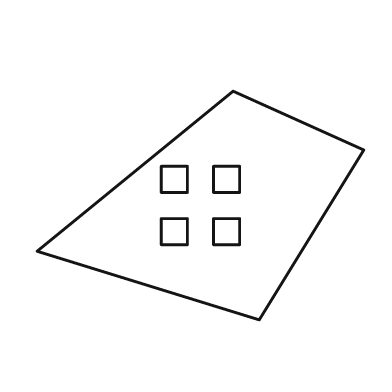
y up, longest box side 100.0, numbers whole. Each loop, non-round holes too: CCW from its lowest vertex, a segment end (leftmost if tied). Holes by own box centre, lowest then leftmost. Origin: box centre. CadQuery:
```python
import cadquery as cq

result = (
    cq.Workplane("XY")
    .moveTo(18.0, -35.0)
    .lineTo(50.0, 17.0)
    .lineTo(10.0, 35.0)
    .lineTo(-50.0, -14.0)
    .close()
    .moveTo(-12.0, -12.0)
    .lineTo(-4.0, -12.0)
    .lineTo(-4.0, -4.0)
    .lineTo(-12.0, -4.0)
    .close()
    .moveTo(4.0, -12.0)
    .lineTo(12.0, -12.0)
    .lineTo(12.0, -4.0)
    .lineTo(4.0, -4.0)
    .close()
    .moveTo(-12.0, 4.0)
    .lineTo(-4.0, 4.0)
    .lineTo(-4.0, 12.0)
    .lineTo(-12.0, 12.0)
    .close()
    .moveTo(4.0, 4.0)
    .lineTo(12.0, 4.0)
    .lineTo(12.0, 12.0)
    .lineTo(4.0, 12.0)
    .close()
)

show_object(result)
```